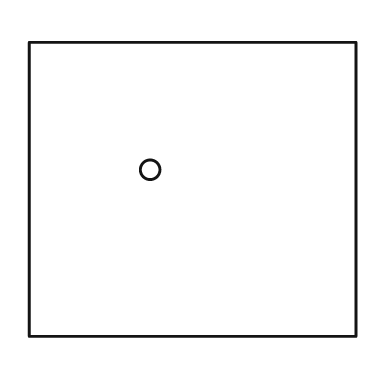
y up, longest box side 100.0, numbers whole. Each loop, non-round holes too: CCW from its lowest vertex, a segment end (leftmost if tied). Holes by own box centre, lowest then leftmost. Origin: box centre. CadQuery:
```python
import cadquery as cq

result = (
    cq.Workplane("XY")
    .moveTo(-50.0, -45.0)
    .lineTo(50.0, -45.0)
    .lineTo(50.0, 45.0)
    .lineTo(-50.0, 45.0)
    .close()
    .moveTo(-13.0, 6.0)
    .circle(3.0)
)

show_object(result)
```